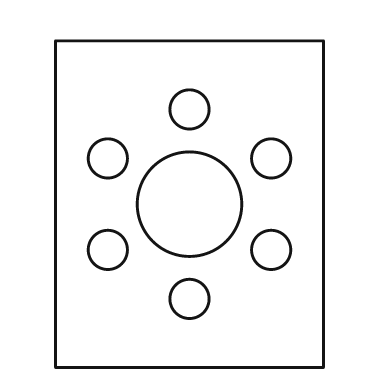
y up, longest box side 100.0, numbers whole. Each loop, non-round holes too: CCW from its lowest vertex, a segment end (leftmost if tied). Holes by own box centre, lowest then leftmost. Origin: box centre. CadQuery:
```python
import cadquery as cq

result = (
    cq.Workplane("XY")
    .moveTo(-41.0, -50.0)
    .lineTo(41.0, -50.0)
    .lineTo(41.0, 50.0)
    .lineTo(-41.0, 50.0)
    .close()
    .moveTo(0.0, -29.0)
    .circle(6.0)
    .moveTo(-25.0, -14.0)
    .circle(6.0)
    .moveTo(25.0, -14.0)
    .circle(6.0)
    .moveTo(0.0, 0.0)
    .circle(16.0)
    .moveTo(-25.0, 14.0)
    .circle(6.0)
    .moveTo(25.0, 14.0)
    .circle(6.0)
    .moveTo(0.0, 29.0)
    .circle(6.0)
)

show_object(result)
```